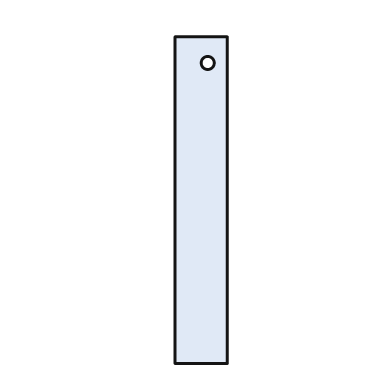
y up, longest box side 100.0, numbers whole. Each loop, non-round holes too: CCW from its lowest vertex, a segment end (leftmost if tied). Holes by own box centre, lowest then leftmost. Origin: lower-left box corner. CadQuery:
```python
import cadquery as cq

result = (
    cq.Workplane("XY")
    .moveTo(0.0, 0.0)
    .lineTo(16.0, 0.0)
    .lineTo(16.0, 100.0)
    .lineTo(0.0, 100.0)
    .close()
    .moveTo(10.0, 92.0)
    .circle(2.0)
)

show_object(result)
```